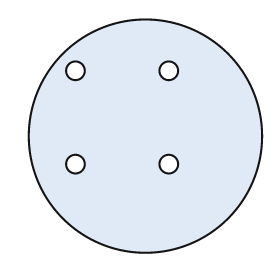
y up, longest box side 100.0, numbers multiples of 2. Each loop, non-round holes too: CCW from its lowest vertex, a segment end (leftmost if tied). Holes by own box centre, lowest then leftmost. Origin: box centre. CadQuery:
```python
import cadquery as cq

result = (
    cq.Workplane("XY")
    .moveTo(0.0, 0.0)
    .circle(50.0)
    .moveTo(-30.0, -12.0)
    .circle(4.0)
    .moveTo(10.0, -12.0)
    .circle(4.0)
    .moveTo(-30.0, 28.0)
    .circle(4.0)
    .moveTo(10.0, 28.0)
    .circle(4.0)
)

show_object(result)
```